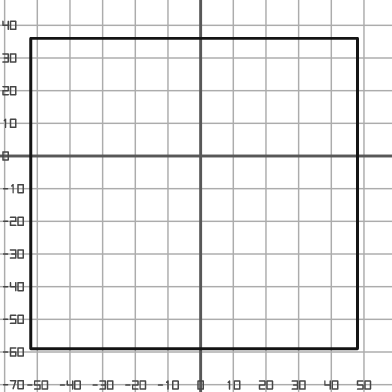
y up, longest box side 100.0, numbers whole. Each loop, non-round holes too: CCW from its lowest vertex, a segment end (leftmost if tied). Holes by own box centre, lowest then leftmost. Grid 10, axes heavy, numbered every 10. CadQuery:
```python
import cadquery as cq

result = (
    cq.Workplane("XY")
    .moveTo(-52.0, -59.0)
    .lineTo(48.0, -59.0)
    .lineTo(48.0, 36.0)
    .lineTo(-52.0, 36.0)
    .close()
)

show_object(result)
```